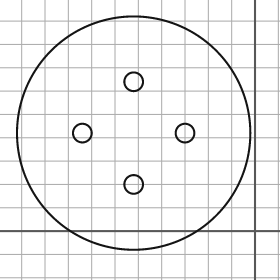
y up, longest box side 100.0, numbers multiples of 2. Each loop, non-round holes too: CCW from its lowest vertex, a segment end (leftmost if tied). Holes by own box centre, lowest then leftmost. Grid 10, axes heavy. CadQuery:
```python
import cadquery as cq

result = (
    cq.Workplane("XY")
    .moveTo(-52.0, 42.0)
    .circle(50.0)
    .moveTo(-52.0, 20.0)
    .circle(4.0)
    .moveTo(-74.0, 42.0)
    .circle(4.0)
    .moveTo(-30.0, 42.0)
    .circle(4.0)
    .moveTo(-52.0, 64.0)
    .circle(4.0)
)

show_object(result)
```